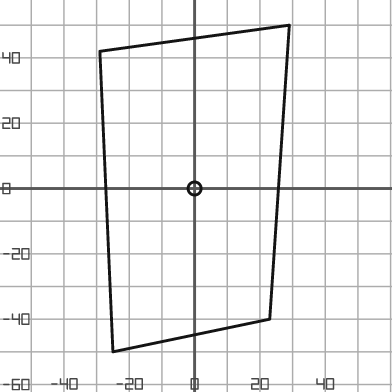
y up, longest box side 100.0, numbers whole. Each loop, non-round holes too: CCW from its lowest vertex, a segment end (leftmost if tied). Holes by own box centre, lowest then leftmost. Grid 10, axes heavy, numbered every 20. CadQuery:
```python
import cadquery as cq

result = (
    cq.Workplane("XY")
    .moveTo(-25.0, -50.0)
    .lineTo(23.0, -40.0)
    .lineTo(29.0, 50.0)
    .lineTo(-29.0, 42.0)
    .close()
    .moveTo(0.0, 0.0)
    .circle(2.0)
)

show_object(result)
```